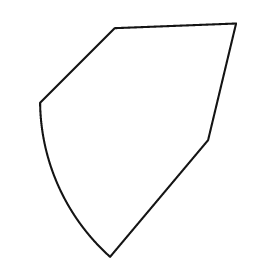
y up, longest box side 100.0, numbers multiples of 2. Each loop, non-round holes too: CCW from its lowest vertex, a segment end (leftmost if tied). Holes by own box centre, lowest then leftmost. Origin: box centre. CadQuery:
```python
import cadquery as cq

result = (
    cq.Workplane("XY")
    .moveTo(-12.0, -50.0)
    .lineTo(30.0, 0.0)
    .lineTo(42.0, 50.0)
    .lineTo(-10.0, 48.0)
    .lineTo(-42.0, 16.0)
    .threePointArc((-34.0, -20.0), (-12.0, -50.0))
    .close()
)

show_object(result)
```